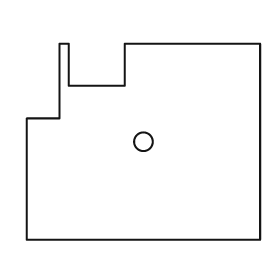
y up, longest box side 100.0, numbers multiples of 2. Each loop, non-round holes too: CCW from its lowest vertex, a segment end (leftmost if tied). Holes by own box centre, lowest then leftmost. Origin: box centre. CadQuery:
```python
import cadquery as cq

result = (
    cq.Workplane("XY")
    .moveTo(-50.0, -42.0)
    .lineTo(50.0, -42.0)
    .lineTo(50.0, 42.0)
    .lineTo(-8.0, 42.0)
    .lineTo(-8.0, 24.0)
    .lineTo(-32.0, 24.0)
    .lineTo(-32.0, 42.0)
    .lineTo(-36.0, 42.0)
    .lineTo(-36.0, 10.0)
    .lineTo(-50.0, 10.0)
    .close()
    .moveTo(0.0, 0.0)
    .circle(4.0)
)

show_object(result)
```